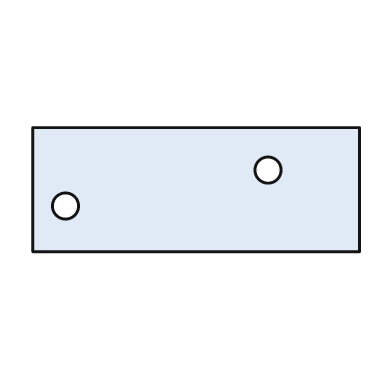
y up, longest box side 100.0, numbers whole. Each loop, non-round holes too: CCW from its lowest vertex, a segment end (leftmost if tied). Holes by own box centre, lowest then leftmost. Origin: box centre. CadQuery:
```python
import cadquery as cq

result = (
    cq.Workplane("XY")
    .moveTo(-50.0, -19.0)
    .lineTo(50.0, -19.0)
    .lineTo(50.0, 19.0)
    .lineTo(-50.0, 19.0)
    .close()
    .moveTo(-40.0, -5.0)
    .circle(4.0)
    .moveTo(22.0, 6.0)
    .circle(4.0)
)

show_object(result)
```